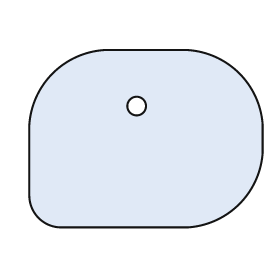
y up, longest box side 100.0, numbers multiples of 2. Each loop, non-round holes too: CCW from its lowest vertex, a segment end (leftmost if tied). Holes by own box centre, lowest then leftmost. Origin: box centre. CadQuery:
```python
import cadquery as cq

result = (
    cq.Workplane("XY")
    .moveTo(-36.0, -38.0)
    .lineTo(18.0, -38.0)
    .threePointArc((40.0, -28.0), (50.0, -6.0))
    .lineTo(50.0, 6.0)
    .threePointArc((40.0, 28.0), (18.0, 38.0))
    .lineTo(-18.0, 38.0)
    .threePointArc((-40.0, 28.0), (-50.0, 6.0))
    .lineTo(-50.0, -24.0)
    .threePointArc((-46.0, -34.0), (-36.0, -38.0))
    .close()
    .moveTo(-4.0, 14.0)
    .circle(4.0)
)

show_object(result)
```